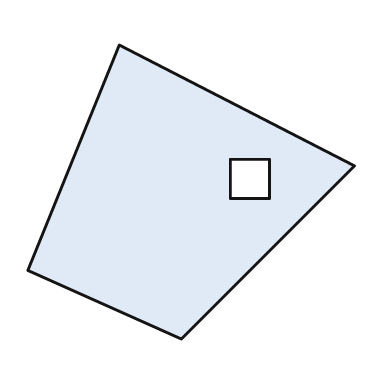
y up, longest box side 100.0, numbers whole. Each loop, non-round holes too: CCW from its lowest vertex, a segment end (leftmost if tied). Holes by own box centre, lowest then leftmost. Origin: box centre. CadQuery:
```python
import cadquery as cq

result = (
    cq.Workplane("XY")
    .moveTo(-3.0, -45.0)
    .lineTo(50.0, 8.0)
    .lineTo(-22.0, 45.0)
    .lineTo(-50.0, -24.0)
    .close()
    .moveTo(12.0, -2.0)
    .lineTo(24.0, -2.0)
    .lineTo(24.0, 10.0)
    .lineTo(12.0, 10.0)
    .close()
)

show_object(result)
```